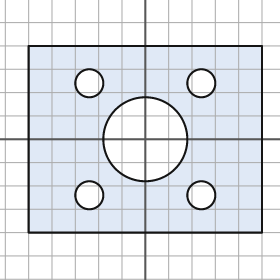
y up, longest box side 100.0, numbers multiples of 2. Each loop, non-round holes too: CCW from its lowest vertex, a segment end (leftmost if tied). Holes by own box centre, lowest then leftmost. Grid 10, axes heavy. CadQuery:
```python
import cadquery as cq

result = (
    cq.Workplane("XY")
    .moveTo(-50.0, -40.0)
    .lineTo(50.0, -40.0)
    .lineTo(50.0, 40.0)
    .lineTo(-50.0, 40.0)
    .close()
    .moveTo(-24.0, -24.0)
    .circle(6.0)
    .moveTo(24.0, -24.0)
    .circle(6.0)
    .moveTo(0.0, 0.0)
    .circle(18.0)
    .moveTo(-24.0, 24.0)
    .circle(6.0)
    .moveTo(24.0, 24.0)
    .circle(6.0)
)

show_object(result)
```